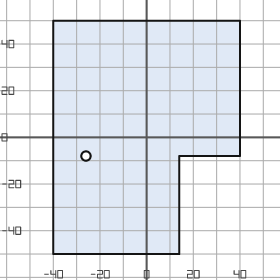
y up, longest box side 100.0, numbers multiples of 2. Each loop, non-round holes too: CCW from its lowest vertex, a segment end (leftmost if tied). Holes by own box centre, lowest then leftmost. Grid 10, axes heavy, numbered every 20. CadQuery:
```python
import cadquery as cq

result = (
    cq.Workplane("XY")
    .moveTo(-40.0, -50.0)
    .lineTo(14.0, -50.0)
    .lineTo(14.0, -8.0)
    .lineTo(40.0, -8.0)
    .lineTo(40.0, 50.0)
    .lineTo(-40.0, 50.0)
    .close()
    .moveTo(-26.0, -8.0)
    .circle(2.0)
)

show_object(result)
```